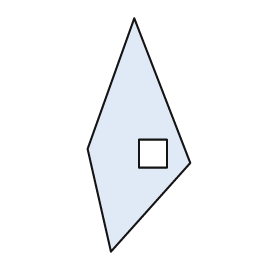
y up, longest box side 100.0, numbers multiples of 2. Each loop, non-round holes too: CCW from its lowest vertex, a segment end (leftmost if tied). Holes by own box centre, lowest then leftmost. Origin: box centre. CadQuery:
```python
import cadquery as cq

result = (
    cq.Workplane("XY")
    .moveTo(-12.0, -50.0)
    .lineTo(22.0, -12.0)
    .lineTo(-2.0, 50.0)
    .lineTo(-22.0, -6.0)
    .close()
    .moveTo(0.0, -14.0)
    .lineTo(12.0, -14.0)
    .lineTo(12.0, -2.0)
    .lineTo(0.0, -2.0)
    .close()
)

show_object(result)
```